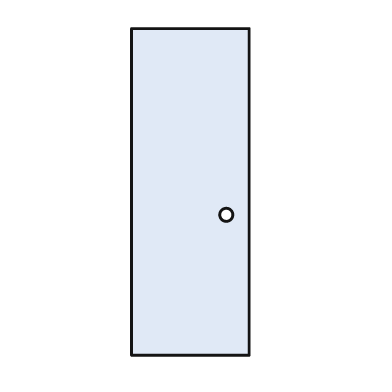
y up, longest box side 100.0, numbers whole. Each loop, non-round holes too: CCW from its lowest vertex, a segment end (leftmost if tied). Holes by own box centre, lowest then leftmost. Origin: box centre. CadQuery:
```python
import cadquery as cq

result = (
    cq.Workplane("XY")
    .moveTo(-18.0, -50.0)
    .lineTo(18.0, -50.0)
    .lineTo(18.0, 50.0)
    .lineTo(-18.0, 50.0)
    .close()
    .moveTo(11.0, -7.0)
    .circle(2.0)
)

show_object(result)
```